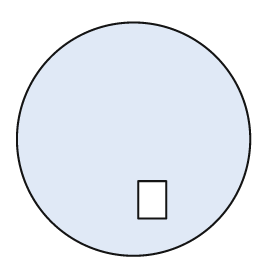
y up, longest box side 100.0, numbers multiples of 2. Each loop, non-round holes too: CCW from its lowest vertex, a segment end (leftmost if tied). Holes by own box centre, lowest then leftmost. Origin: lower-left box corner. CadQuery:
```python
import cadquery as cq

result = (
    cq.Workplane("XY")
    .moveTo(50.0, 50.0)
    .circle(50.0)
    .moveTo(52.0, 16.0)
    .lineTo(64.0, 16.0)
    .lineTo(64.0, 32.0)
    .lineTo(52.0, 32.0)
    .close()
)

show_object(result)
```